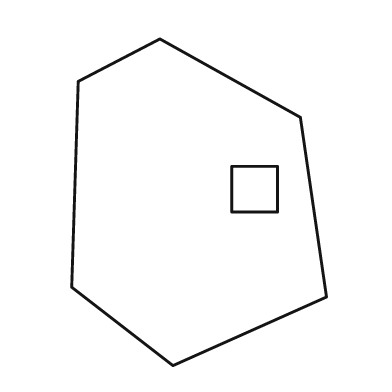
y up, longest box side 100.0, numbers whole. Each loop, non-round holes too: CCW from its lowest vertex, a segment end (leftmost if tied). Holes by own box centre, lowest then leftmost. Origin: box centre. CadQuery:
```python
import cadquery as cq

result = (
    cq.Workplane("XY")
    .moveTo(-8.0, -50.0)
    .lineTo(39.0, -29.0)
    .lineTo(31.0, 26.0)
    .lineTo(-12.0, 50.0)
    .lineTo(-37.0, 37.0)
    .lineTo(-39.0, -26.0)
    .close()
    .moveTo(10.0, -3.0)
    .lineTo(24.0, -3.0)
    .lineTo(24.0, 11.0)
    .lineTo(10.0, 11.0)
    .close()
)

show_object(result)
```